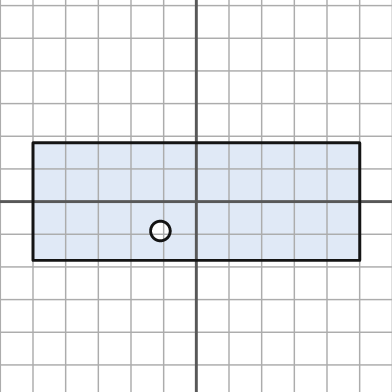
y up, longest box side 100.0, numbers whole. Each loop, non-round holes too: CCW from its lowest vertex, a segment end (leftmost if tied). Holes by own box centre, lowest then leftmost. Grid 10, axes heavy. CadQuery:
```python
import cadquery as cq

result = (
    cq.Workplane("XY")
    .moveTo(-50.0, -18.0)
    .lineTo(50.0, -18.0)
    .lineTo(50.0, 18.0)
    .lineTo(-50.0, 18.0)
    .close()
    .moveTo(-11.0, -9.0)
    .circle(3.0)
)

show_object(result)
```